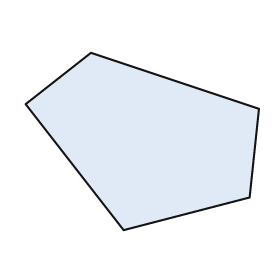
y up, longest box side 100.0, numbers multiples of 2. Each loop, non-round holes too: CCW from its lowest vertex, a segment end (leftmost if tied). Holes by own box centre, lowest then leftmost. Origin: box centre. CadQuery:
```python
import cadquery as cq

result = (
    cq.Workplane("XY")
    .moveTo(-8.0, -38.0)
    .lineTo(46.0, -24.0)
    .lineTo(50.0, 14.0)
    .lineTo(-22.0, 38.0)
    .lineTo(-50.0, 16.0)
    .close()
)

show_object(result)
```